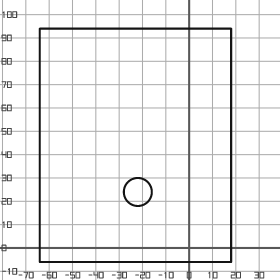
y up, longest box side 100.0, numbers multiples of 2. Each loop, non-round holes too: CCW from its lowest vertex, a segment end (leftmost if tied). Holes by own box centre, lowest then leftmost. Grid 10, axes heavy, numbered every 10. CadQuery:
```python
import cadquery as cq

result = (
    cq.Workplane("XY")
    .moveTo(-64.0, -6.0)
    .lineTo(18.0, -6.0)
    .lineTo(18.0, 94.0)
    .lineTo(-64.0, 94.0)
    .close()
    .moveTo(-22.0, 24.0)
    .circle(6.0)
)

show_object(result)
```